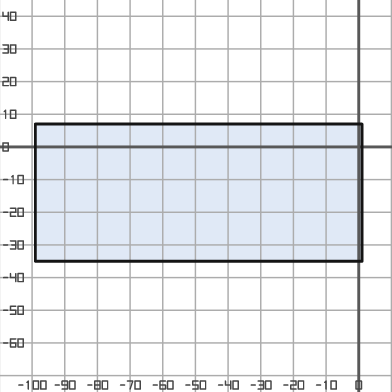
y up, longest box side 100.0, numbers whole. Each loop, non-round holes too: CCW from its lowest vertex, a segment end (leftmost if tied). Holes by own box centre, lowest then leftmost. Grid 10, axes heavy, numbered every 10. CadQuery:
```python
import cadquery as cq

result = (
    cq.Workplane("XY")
    .moveTo(-99.0, -35.0)
    .lineTo(1.0, -35.0)
    .lineTo(1.0, 7.0)
    .lineTo(-99.0, 7.0)
    .close()
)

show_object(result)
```